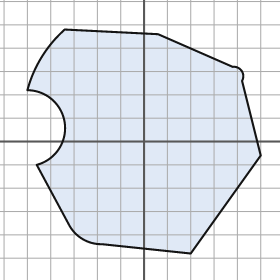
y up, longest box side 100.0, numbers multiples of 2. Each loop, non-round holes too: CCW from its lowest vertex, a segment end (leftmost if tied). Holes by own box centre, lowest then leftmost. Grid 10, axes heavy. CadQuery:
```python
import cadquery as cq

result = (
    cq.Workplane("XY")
    .moveTo(20.0, -48.0)
    .lineTo(50.0, -6.0)
    .lineTo(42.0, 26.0)
    .threePointArc((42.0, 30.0), (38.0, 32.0))
    .lineTo(6.0, 46.0)
    .lineTo(-34.0, 48.0)
    .threePointArc((-44.0, 36.0), (-50.0, 22.0))
    .threePointArc((-34.0, 8.0), (-46.0, -10.0))
    .lineTo(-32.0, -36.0)
    .threePointArc((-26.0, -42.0), (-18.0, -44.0))
    .close()
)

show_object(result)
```